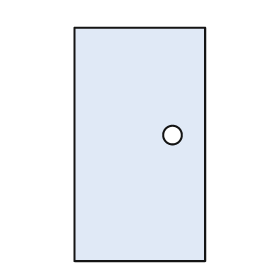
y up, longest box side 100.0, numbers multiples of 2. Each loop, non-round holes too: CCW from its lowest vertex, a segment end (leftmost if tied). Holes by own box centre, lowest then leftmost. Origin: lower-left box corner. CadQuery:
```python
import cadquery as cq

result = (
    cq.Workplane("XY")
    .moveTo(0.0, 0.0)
    .lineTo(56.0, 0.0)
    .lineTo(56.0, 100.0)
    .lineTo(0.0, 100.0)
    .close()
    .moveTo(42.0, 54.0)
    .circle(4.0)
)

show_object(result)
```